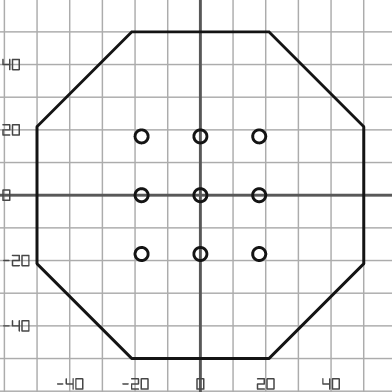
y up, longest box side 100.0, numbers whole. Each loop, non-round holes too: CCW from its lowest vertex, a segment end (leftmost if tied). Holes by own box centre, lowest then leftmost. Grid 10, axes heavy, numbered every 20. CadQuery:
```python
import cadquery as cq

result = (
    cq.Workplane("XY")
    .moveTo(-21.0, -50.0)
    .lineTo(21.0, -50.0)
    .lineTo(50.0, -21.0)
    .lineTo(50.0, 21.0)
    .lineTo(21.0, 50.0)
    .lineTo(-21.0, 50.0)
    .lineTo(-50.0, 21.0)
    .lineTo(-50.0, -21.0)
    .close()
    .moveTo(-18.0, -18.0)
    .circle(2.0)
    .moveTo(0.0, -18.0)
    .circle(2.0)
    .moveTo(18.0, -18.0)
    .circle(2.0)
    .moveTo(-18.0, 0.0)
    .circle(2.0)
    .moveTo(0.0, 0.0)
    .circle(2.0)
    .moveTo(18.0, 0.0)
    .circle(2.0)
    .moveTo(-18.0, 18.0)
    .circle(2.0)
    .moveTo(0.0, 18.0)
    .circle(2.0)
    .moveTo(18.0, 18.0)
    .circle(2.0)
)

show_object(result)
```